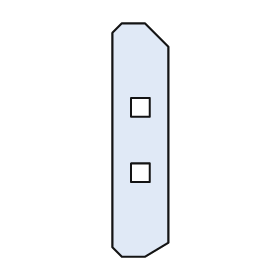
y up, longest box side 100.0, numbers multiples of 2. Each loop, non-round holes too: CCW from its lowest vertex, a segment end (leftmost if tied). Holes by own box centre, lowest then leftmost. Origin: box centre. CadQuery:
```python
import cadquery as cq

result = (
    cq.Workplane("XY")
    .moveTo(-8.0, -50.0)
    .lineTo(2.0, -50.0)
    .lineTo(12.0, -44.0)
    .lineTo(12.0, 40.0)
    .lineTo(2.0, 50.0)
    .lineTo(-8.0, 50.0)
    .lineTo(-12.0, 46.0)
    .lineTo(-12.0, -46.0)
    .close()
    .moveTo(-4.0, -18.0)
    .lineTo(4.0, -18.0)
    .lineTo(4.0, -10.0)
    .lineTo(-4.0, -10.0)
    .close()
    .moveTo(-4.0, 10.0)
    .lineTo(4.0, 10.0)
    .lineTo(4.0, 18.0)
    .lineTo(-4.0, 18.0)
    .close()
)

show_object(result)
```